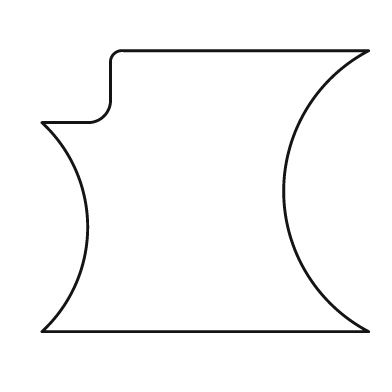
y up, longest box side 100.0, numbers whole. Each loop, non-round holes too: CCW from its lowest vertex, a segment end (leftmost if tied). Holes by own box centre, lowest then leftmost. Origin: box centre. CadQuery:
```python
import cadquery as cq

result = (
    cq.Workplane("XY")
    .moveTo(-50.0, -43.0)
    .lineTo(50.0, -43.0)
    .threePointArc((24.0, 0.0), (50.0, 43.0))
    .lineTo(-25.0, 43.0)
    .threePointArc((-28.0, 42.0), (-29.0, 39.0))
    .lineTo(-29.0, 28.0)
    .threePointArc((-31.0, 23.0), (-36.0, 21.0))
    .lineTo(-50.0, 21.0)
    .threePointArc((-36.0, -11.0), (-50.0, -43.0))
    .close()
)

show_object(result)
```